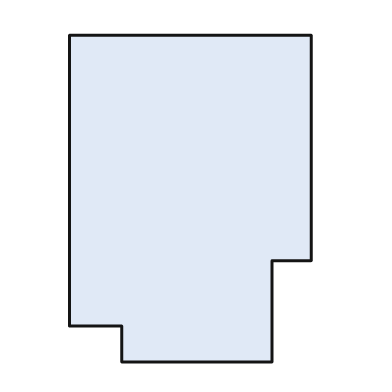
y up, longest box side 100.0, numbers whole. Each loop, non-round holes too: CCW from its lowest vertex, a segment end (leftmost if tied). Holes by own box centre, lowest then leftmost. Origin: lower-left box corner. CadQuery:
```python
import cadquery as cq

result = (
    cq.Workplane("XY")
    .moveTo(16.0, 0.0)
    .lineTo(62.0, 0.0)
    .lineTo(62.0, 31.0)
    .lineTo(74.0, 31.0)
    .lineTo(74.0, 100.0)
    .lineTo(0.0, 100.0)
    .lineTo(0.0, 11.0)
    .lineTo(16.0, 11.0)
    .close()
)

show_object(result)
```